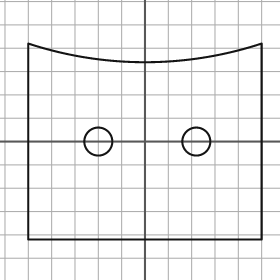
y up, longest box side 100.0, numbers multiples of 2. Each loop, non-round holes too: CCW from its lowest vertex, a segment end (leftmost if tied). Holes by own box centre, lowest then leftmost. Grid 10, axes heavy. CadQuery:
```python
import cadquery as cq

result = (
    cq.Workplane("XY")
    .moveTo(-50.0, -42.0)
    .lineTo(50.0, -42.0)
    .lineTo(50.0, 42.0)
    .threePointArc((0.0, 34.0), (-50.0, 42.0))
    .close()
    .moveTo(-20.0, 0.0)
    .circle(6.0)
    .moveTo(22.0, 0.0)
    .circle(6.0)
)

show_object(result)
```